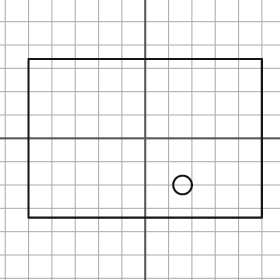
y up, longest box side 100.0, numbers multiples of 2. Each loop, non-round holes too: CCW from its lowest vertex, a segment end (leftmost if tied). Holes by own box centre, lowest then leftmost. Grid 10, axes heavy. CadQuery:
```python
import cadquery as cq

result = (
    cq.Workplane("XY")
    .moveTo(-50.0, -34.0)
    .lineTo(50.0, -34.0)
    .lineTo(50.0, 34.0)
    .lineTo(-50.0, 34.0)
    .close()
    .moveTo(16.0, -20.0)
    .circle(4.0)
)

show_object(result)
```